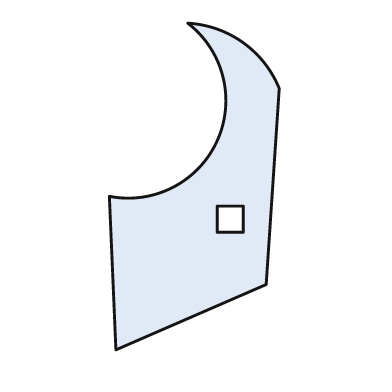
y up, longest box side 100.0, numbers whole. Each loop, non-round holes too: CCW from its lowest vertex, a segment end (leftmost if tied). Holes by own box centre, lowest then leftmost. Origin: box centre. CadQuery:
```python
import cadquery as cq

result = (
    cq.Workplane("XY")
    .moveTo(-24.0, -50.0)
    .lineTo(22.0, -30.0)
    .lineTo(26.0, 30.0)
    .threePointArc((15.0, 44.0), (-2.0, 50.0))
    .threePointArc((7.0, 14.0), (-26.0, -3.0))
    .close()
    .moveTo(7.0, -14.0)
    .lineTo(15.0, -14.0)
    .lineTo(15.0, -6.0)
    .lineTo(7.0, -6.0)
    .close()
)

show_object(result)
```